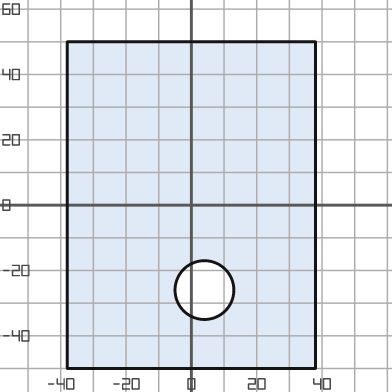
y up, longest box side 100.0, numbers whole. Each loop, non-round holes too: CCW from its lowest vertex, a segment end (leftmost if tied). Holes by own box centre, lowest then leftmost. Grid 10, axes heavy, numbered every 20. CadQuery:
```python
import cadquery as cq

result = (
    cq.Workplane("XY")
    .moveTo(-38.0, -50.0)
    .lineTo(38.0, -50.0)
    .lineTo(38.0, 50.0)
    .lineTo(-38.0, 50.0)
    .close()
    .moveTo(4.0, -26.0)
    .circle(9.0)
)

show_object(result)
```